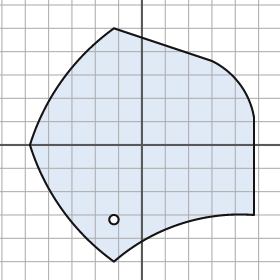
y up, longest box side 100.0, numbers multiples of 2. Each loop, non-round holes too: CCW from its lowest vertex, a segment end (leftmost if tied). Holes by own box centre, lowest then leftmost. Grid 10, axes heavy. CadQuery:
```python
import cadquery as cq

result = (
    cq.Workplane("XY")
    .moveTo(-12.0, -50.0)
    .threePointArc((16.0, -34.0), (48.0, -30.0))
    .lineTo(48.0, 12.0)
    .threePointArc((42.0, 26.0), (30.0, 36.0))
    .lineTo(-12.0, 50.0)
    .threePointArc((-34.0, 28.0), (-48.0, 0.0))
    .threePointArc((-34.0, -28.0), (-12.0, -50.0))
    .close()
    .moveTo(-12.0, -32.0)
    .circle(2.0)
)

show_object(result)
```